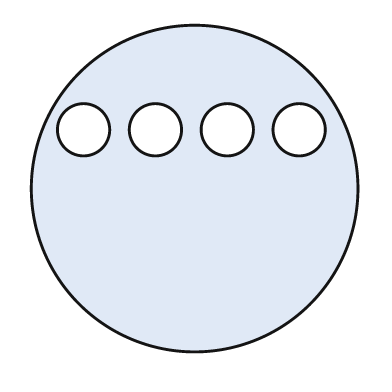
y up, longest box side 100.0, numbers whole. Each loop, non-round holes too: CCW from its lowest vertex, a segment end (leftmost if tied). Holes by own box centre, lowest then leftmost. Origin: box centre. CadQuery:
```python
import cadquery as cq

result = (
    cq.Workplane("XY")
    .moveTo(0.0, 0.0)
    .circle(50.0)
    .moveTo(-34.0, 18.0)
    .circle(8.0)
    .moveTo(-12.0, 18.0)
    .circle(8.0)
    .moveTo(10.0, 18.0)
    .circle(8.0)
    .moveTo(32.0, 18.0)
    .circle(8.0)
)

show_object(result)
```